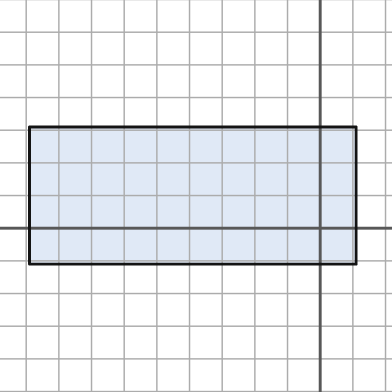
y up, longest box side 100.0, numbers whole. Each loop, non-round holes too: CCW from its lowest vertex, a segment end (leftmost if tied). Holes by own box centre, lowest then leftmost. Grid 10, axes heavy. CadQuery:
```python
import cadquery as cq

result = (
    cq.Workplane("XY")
    .moveTo(-89.0, -11.0)
    .lineTo(11.0, -11.0)
    .lineTo(11.0, 31.0)
    .lineTo(-89.0, 31.0)
    .close()
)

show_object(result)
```